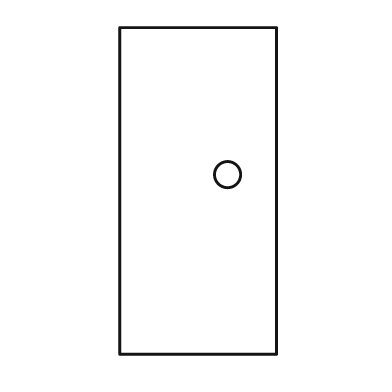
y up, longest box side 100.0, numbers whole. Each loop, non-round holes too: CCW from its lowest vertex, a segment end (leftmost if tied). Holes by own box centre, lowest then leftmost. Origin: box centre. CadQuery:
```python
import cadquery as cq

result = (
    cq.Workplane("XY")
    .moveTo(-24.0, -50.0)
    .lineTo(24.0, -50.0)
    .lineTo(24.0, 50.0)
    .lineTo(-24.0, 50.0)
    .close()
    .moveTo(9.0, 5.0)
    .circle(4.0)
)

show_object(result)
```